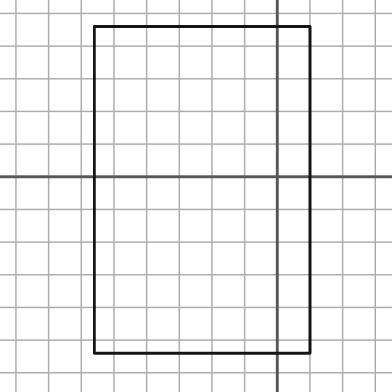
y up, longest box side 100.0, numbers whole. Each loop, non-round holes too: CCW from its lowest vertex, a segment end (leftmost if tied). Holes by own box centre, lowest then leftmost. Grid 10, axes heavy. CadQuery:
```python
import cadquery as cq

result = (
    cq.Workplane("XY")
    .moveTo(-56.0, -54.0)
    .lineTo(10.0, -54.0)
    .lineTo(10.0, 46.0)
    .lineTo(-56.0, 46.0)
    .close()
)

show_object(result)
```